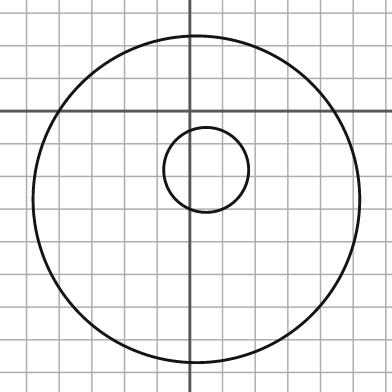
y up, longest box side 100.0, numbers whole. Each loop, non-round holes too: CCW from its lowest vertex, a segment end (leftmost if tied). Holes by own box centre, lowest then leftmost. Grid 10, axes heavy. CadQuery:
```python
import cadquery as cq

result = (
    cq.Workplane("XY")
    .moveTo(2.0, -27.0)
    .circle(50.0)
    .moveTo(5.0, -18.0)
    .circle(13.0)
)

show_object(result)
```